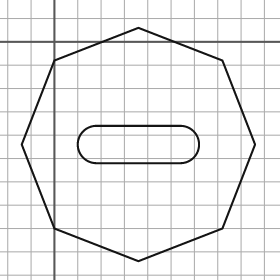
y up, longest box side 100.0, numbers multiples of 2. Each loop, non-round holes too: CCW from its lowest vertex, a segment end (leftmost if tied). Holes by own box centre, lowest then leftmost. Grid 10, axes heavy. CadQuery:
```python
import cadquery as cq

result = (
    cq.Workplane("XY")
    .moveTo(36.0, -94.0)
    .lineTo(72.0, -80.0)
    .lineTo(86.0, -44.0)
    .lineTo(72.0, -8.0)
    .lineTo(36.0, 6.0)
    .lineTo(0.0, -8.0)
    .lineTo(-14.0, -44.0)
    .lineTo(0.0, -80.0)
    .close()
    .moveTo(18.0, -52.0)
    .lineTo(54.0, -52.0)
    .threePointArc((62.0, -44.0), (54.0, -36.0))
    .lineTo(18.0, -36.0)
    .threePointArc((10.0, -44.0), (18.0, -52.0))
    .close()
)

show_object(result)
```